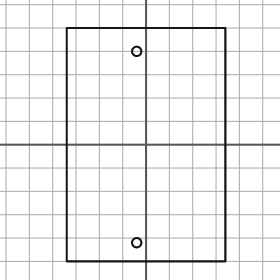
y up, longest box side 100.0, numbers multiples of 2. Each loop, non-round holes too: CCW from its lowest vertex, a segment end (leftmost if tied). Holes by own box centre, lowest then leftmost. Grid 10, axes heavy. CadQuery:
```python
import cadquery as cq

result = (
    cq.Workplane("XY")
    .moveTo(-34.0, -50.0)
    .lineTo(34.0, -50.0)
    .lineTo(34.0, 50.0)
    .lineTo(-34.0, 50.0)
    .close()
    .moveTo(-4.0, -42.0)
    .circle(2.0)
    .moveTo(-4.0, 40.0)
    .circle(2.0)
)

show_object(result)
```